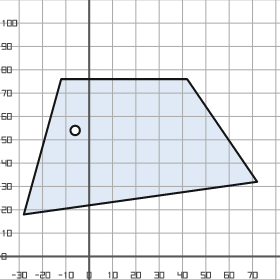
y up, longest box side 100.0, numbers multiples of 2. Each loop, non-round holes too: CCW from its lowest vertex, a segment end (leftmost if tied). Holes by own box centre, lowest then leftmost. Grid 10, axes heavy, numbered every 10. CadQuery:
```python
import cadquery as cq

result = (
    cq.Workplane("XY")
    .moveTo(-28.0, 18.0)
    .lineTo(72.0, 32.0)
    .lineTo(42.0, 76.0)
    .lineTo(-12.0, 76.0)
    .close()
    .moveTo(-6.0, 54.0)
    .circle(2.0)
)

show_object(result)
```